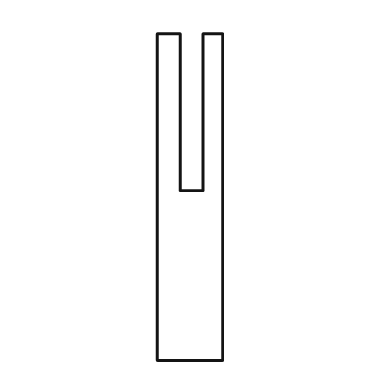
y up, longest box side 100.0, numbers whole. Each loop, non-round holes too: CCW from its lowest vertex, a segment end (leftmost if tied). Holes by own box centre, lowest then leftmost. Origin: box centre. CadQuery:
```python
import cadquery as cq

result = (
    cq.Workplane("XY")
    .moveTo(-10.0, -50.0)
    .lineTo(10.0, -50.0)
    .lineTo(10.0, 50.0)
    .lineTo(4.0, 50.0)
    .lineTo(4.0, 2.0)
    .lineTo(-3.0, 2.0)
    .lineTo(-3.0, 50.0)
    .lineTo(-10.0, 50.0)
    .close()
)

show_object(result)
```